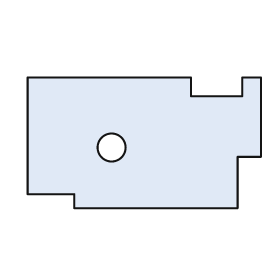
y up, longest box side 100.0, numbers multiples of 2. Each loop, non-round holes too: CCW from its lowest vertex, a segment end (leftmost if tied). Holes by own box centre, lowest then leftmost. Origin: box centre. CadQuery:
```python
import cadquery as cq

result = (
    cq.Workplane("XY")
    .moveTo(-30.0, -28.0)
    .lineTo(40.0, -28.0)
    .lineTo(40.0, -6.0)
    .lineTo(50.0, -6.0)
    .lineTo(50.0, 28.0)
    .lineTo(42.0, 28.0)
    .lineTo(42.0, 20.0)
    .lineTo(20.0, 20.0)
    .lineTo(20.0, 28.0)
    .lineTo(-50.0, 28.0)
    .lineTo(-50.0, -22.0)
    .lineTo(-30.0, -22.0)
    .close()
    .moveTo(-14.0, -2.0)
    .circle(6.0)
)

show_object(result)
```